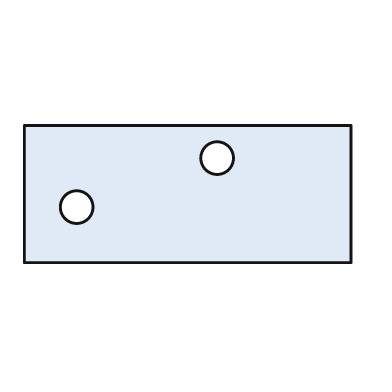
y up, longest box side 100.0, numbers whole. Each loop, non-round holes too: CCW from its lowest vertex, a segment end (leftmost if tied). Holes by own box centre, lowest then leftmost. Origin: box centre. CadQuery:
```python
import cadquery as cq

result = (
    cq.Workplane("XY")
    .moveTo(-50.0, -21.0)
    .lineTo(50.0, -21.0)
    .lineTo(50.0, 21.0)
    .lineTo(-50.0, 21.0)
    .close()
    .moveTo(-34.0, -4.0)
    .circle(5.0)
    .moveTo(9.0, 11.0)
    .circle(5.0)
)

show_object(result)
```